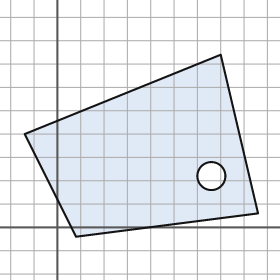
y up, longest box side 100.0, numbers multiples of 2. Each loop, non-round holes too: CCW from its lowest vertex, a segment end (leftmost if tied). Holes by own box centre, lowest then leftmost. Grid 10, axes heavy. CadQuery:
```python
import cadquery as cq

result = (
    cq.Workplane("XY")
    .moveTo(8.0, -4.0)
    .lineTo(86.0, 6.0)
    .lineTo(70.0, 74.0)
    .lineTo(-14.0, 40.0)
    .close()
    .moveTo(66.0, 22.0)
    .circle(6.0)
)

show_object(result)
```